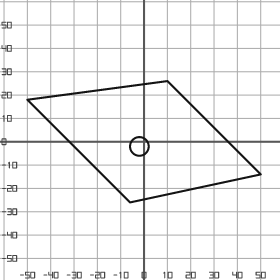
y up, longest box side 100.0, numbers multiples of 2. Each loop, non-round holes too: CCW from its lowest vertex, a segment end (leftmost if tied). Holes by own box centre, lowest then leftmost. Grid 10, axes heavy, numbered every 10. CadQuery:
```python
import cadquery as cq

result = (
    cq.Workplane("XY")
    .moveTo(-6.0, -26.0)
    .lineTo(50.0, -14.0)
    .lineTo(10.0, 26.0)
    .lineTo(-50.0, 18.0)
    .close()
    .moveTo(-2.0, -2.0)
    .circle(4.0)
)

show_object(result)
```